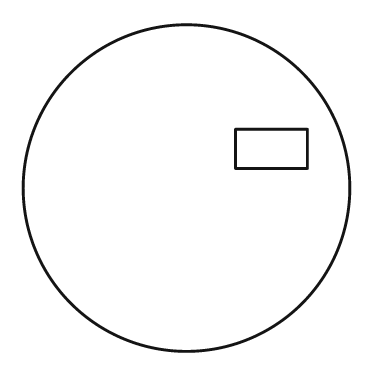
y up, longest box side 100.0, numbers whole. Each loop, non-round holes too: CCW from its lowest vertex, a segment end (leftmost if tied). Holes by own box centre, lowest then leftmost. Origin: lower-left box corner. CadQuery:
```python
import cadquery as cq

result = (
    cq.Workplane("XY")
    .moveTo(50.0, 50.0)
    .circle(50.0)
    .moveTo(65.0, 56.0)
    .lineTo(87.0, 56.0)
    .lineTo(87.0, 68.0)
    .lineTo(65.0, 68.0)
    .close()
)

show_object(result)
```